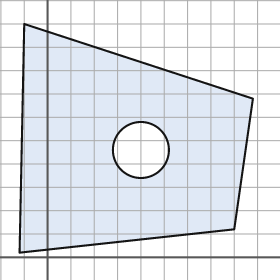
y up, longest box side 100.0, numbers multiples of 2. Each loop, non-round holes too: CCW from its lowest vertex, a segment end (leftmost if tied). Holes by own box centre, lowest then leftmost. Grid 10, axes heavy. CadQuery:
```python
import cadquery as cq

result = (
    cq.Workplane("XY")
    .moveTo(-12.0, 2.0)
    .lineTo(80.0, 12.0)
    .lineTo(88.0, 68.0)
    .lineTo(-10.0, 100.0)
    .close()
    .moveTo(40.0, 46.0)
    .circle(12.0)
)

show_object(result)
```